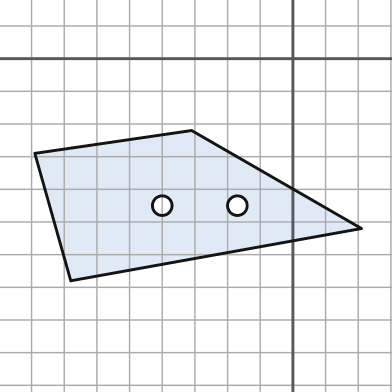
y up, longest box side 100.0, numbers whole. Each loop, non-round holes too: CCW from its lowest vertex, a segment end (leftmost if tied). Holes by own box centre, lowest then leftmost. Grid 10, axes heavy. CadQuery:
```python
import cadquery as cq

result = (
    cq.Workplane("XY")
    .moveTo(-68.0, -68.0)
    .lineTo(21.0, -52.0)
    .lineTo(-31.0, -22.0)
    .lineTo(-79.0, -29.0)
    .close()
    .moveTo(-40.0, -45.0)
    .circle(3.0)
    .moveTo(-17.0, -45.0)
    .circle(3.0)
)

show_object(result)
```